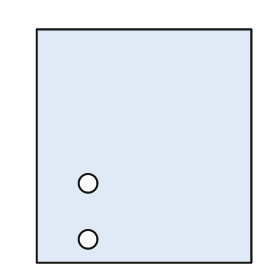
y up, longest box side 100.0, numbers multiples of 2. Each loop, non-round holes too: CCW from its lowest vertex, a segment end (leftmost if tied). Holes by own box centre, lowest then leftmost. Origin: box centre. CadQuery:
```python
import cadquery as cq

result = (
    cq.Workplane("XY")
    .moveTo(-46.0, -50.0)
    .lineTo(46.0, -50.0)
    .lineTo(46.0, 50.0)
    .lineTo(-46.0, 50.0)
    .close()
    .moveTo(-24.0, -40.0)
    .circle(4.0)
    .moveTo(-24.0, -16.0)
    .circle(4.0)
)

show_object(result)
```